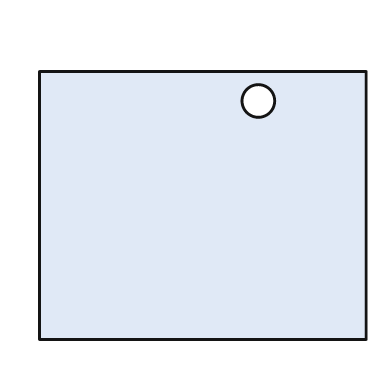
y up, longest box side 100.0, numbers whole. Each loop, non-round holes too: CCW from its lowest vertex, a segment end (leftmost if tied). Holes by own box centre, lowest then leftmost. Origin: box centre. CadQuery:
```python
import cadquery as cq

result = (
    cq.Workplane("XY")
    .moveTo(-50.0, -41.0)
    .lineTo(50.0, -41.0)
    .lineTo(50.0, 41.0)
    .lineTo(-50.0, 41.0)
    .close()
    .moveTo(17.0, 32.0)
    .circle(5.0)
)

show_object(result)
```